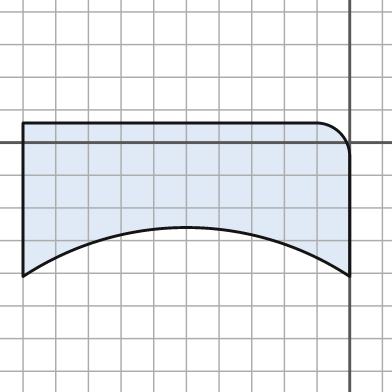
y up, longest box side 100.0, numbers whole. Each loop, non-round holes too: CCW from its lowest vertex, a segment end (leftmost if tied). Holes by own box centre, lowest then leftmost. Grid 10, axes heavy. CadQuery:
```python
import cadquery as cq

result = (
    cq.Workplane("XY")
    .moveTo(-100.0, -41.0)
    .threePointArc((-50.0, -26.0), (0.0, -41.0))
    .lineTo(0.0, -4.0)
    .threePointArc((-3.0, 3.0), (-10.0, 6.0))
    .lineTo(-100.0, 6.0)
    .close()
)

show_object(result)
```